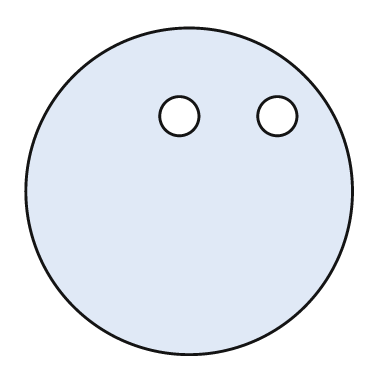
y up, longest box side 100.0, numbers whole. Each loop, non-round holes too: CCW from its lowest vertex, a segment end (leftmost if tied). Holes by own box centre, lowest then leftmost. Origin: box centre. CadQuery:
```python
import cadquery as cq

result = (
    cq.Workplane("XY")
    .moveTo(0.0, 0.0)
    .circle(50.0)
    .moveTo(-3.0, 23.0)
    .circle(6.0)
    .moveTo(27.0, 23.0)
    .circle(6.0)
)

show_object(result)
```